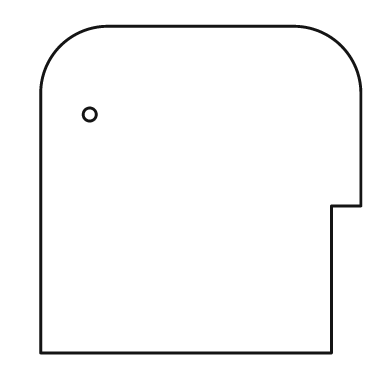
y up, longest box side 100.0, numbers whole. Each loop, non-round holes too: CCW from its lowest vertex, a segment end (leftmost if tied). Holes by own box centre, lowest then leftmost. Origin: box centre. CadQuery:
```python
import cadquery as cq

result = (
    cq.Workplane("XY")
    .moveTo(-49.0, -50.0)
    .lineTo(40.0, -50.0)
    .lineTo(40.0, -5.0)
    .lineTo(49.0, -5.0)
    .lineTo(49.0, 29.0)
    .threePointArc((43.0, 44.0), (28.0, 50.0))
    .lineTo(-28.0, 50.0)
    .threePointArc((-43.0, 44.0), (-49.0, 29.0))
    .close()
    .moveTo(-34.0, 23.0)
    .circle(2.0)
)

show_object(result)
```